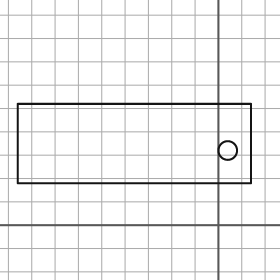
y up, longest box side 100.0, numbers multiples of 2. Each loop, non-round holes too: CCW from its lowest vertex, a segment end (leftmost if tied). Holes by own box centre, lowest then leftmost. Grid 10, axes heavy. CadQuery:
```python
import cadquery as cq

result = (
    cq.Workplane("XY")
    .moveTo(-86.0, 18.0)
    .lineTo(14.0, 18.0)
    .lineTo(14.0, 52.0)
    .lineTo(-86.0, 52.0)
    .close()
    .moveTo(4.0, 32.0)
    .circle(4.0)
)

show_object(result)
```